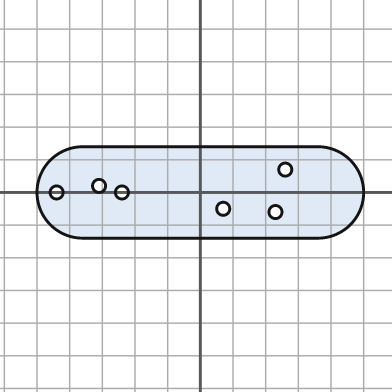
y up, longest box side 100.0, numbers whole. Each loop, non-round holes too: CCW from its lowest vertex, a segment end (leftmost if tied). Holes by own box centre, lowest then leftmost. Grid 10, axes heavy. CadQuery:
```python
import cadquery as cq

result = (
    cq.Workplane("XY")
    .moveTo(-36.0, -14.0)
    .lineTo(36.0, -14.0)
    .threePointArc((50.0, 0.0), (36.0, 14.0))
    .lineTo(-36.0, 14.0)
    .threePointArc((-50.0, 0.0), (-36.0, -14.0))
    .close()
    .moveTo(23.0, -6.0)
    .circle(2.0)
    .moveTo(7.0, -5.0)
    .circle(2.0)
    .moveTo(-44.0, 0.0)
    .circle(2.0)
    .moveTo(-24.0, 0.0)
    .circle(2.0)
    .moveTo(-31.0, 2.0)
    .circle(2.0)
    .moveTo(26.0, 7.0)
    .circle(2.0)
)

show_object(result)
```